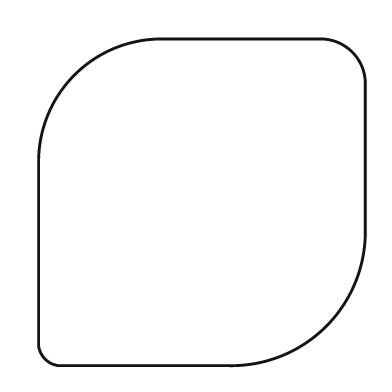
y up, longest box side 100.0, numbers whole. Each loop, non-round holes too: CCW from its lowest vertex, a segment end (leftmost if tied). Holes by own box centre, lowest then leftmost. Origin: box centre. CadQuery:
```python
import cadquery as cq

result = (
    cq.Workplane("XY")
    .moveTo(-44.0, -50.0)
    .lineTo(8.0, -50.0)
    .threePointArc((38.0, -38.0), (50.0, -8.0))
    .lineTo(50.0, 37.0)
    .threePointArc((46.0, 46.0), (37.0, 50.0))
    .lineTo(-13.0, 50.0)
    .threePointArc((-39.0, 39.0), (-50.0, 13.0))
    .lineTo(-50.0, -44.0)
    .threePointArc((-48.0, -48.0), (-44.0, -50.0))
    .close()
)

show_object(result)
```